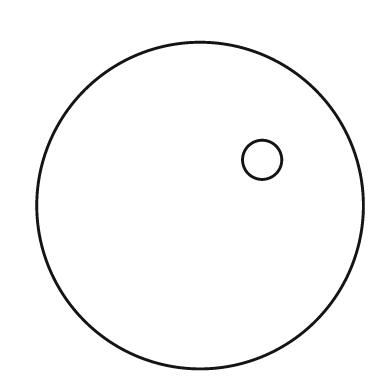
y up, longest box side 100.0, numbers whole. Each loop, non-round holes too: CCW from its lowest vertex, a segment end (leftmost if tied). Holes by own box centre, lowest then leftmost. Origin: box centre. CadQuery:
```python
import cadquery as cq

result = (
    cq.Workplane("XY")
    .moveTo(0.0, 0.0)
    .circle(50.0)
    .moveTo(19.0, 14.0)
    .circle(6.0)
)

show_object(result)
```